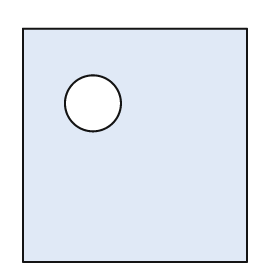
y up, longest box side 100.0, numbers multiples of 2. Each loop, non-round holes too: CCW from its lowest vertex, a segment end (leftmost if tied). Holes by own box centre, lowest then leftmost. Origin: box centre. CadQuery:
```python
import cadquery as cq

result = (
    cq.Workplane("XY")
    .moveTo(-48.0, -50.0)
    .lineTo(48.0, -50.0)
    .lineTo(48.0, 50.0)
    .lineTo(-48.0, 50.0)
    .close()
    .moveTo(-18.0, 18.0)
    .circle(12.0)
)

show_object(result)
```